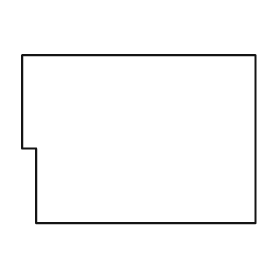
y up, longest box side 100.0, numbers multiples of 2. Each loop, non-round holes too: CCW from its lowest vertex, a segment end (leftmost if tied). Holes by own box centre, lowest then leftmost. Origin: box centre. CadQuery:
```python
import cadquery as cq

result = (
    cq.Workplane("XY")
    .moveTo(-44.0, -36.0)
    .lineTo(50.0, -36.0)
    .lineTo(50.0, 36.0)
    .lineTo(-50.0, 36.0)
    .lineTo(-50.0, -4.0)
    .lineTo(-44.0, -4.0)
    .close()
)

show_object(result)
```